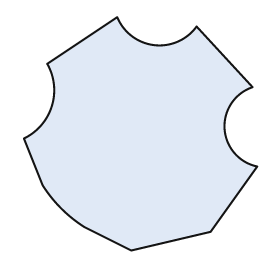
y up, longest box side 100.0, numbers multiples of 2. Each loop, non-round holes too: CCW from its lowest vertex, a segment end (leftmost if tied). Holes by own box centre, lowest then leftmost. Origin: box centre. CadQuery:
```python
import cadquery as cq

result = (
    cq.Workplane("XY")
    .moveTo(-4.0, -50.0)
    .lineTo(30.0, -42.0)
    .lineTo(50.0, -14.0)
    .threePointArc((36.0, 2.0), (48.0, 20.0))
    .lineTo(24.0, 46.0)
    .threePointArc((6.0, 38.0), (-10.0, 50.0))
    .lineTo(-40.0, 30.0)
    .threePointArc((-38.0, 12.0), (-50.0, -2.0))
    .lineTo(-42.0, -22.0)
    .threePointArc((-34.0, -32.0), (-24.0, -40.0))
    .close()
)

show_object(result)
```